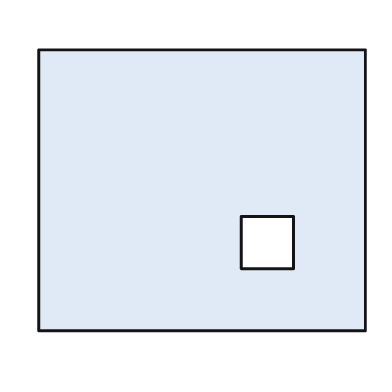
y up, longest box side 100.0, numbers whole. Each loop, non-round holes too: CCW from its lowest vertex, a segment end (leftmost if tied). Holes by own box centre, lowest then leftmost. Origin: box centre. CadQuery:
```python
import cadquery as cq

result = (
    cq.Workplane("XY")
    .moveTo(-50.0, -43.0)
    .lineTo(50.0, -43.0)
    .lineTo(50.0, 43.0)
    .lineTo(-50.0, 43.0)
    .close()
    .moveTo(12.0, -24.0)
    .lineTo(28.0, -24.0)
    .lineTo(28.0, -8.0)
    .lineTo(12.0, -8.0)
    .close()
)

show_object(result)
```